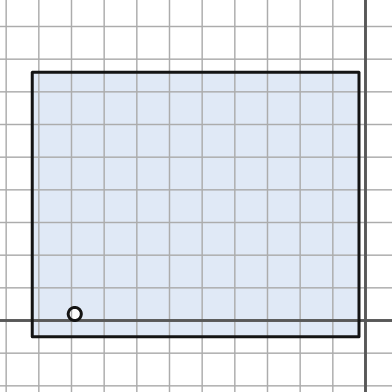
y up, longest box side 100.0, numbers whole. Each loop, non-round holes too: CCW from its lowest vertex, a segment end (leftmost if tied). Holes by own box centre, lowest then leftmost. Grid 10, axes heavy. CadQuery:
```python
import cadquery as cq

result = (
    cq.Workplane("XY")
    .moveTo(-102.0, -5.0)
    .lineTo(-2.0, -5.0)
    .lineTo(-2.0, 76.0)
    .lineTo(-102.0, 76.0)
    .close()
    .moveTo(-89.0, 2.0)
    .circle(2.0)
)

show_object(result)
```